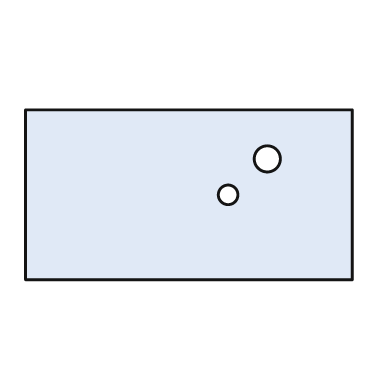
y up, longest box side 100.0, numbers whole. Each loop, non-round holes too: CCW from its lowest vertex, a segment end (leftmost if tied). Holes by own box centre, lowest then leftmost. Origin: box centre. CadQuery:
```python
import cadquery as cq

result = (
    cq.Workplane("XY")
    .moveTo(-50.0, -26.0)
    .lineTo(50.0, -26.0)
    .lineTo(50.0, 26.0)
    .lineTo(-50.0, 26.0)
    .close()
    .moveTo(12.0, 0.0)
    .circle(3.0)
    .moveTo(24.0, 11.0)
    .circle(4.0)
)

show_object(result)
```